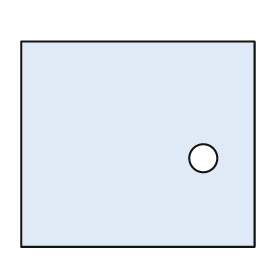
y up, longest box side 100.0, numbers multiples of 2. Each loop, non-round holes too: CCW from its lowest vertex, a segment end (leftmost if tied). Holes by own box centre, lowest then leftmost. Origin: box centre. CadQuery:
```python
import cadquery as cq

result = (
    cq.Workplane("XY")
    .moveTo(-50.0, -44.0)
    .lineTo(50.0, -44.0)
    .lineTo(50.0, 44.0)
    .lineTo(-50.0, 44.0)
    .close()
    .moveTo(28.0, -6.0)
    .circle(6.0)
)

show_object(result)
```